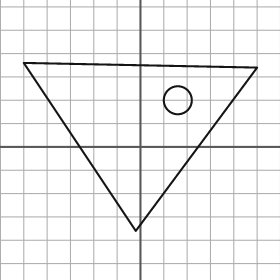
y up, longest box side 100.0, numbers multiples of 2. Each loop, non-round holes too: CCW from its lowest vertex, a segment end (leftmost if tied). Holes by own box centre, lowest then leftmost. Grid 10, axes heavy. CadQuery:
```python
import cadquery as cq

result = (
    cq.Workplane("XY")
    .moveTo(-2.0, -36.0)
    .lineTo(50.0, 34.0)
    .lineTo(-50.0, 36.0)
    .close()
    .moveTo(16.0, 20.0)
    .circle(6.0)
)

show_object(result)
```